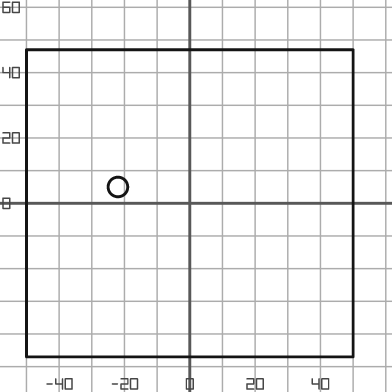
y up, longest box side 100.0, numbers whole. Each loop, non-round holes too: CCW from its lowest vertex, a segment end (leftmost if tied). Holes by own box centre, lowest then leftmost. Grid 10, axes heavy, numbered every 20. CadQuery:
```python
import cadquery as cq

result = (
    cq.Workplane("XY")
    .moveTo(-50.0, -47.0)
    .lineTo(50.0, -47.0)
    .lineTo(50.0, 47.0)
    .lineTo(-50.0, 47.0)
    .close()
    .moveTo(-22.0, 5.0)
    .circle(3.0)
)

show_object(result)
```